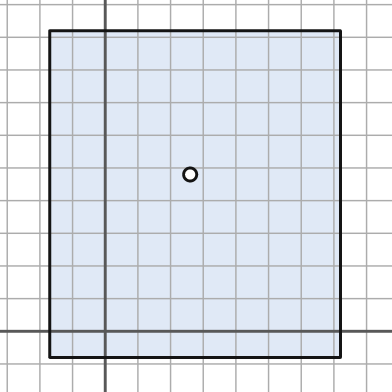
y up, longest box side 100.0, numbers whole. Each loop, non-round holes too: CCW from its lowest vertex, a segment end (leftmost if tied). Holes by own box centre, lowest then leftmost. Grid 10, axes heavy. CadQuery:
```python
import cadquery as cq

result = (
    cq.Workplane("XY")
    .moveTo(-17.0, -8.0)
    .lineTo(72.0, -8.0)
    .lineTo(72.0, 92.0)
    .lineTo(-17.0, 92.0)
    .close()
    .moveTo(26.0, 48.0)
    .circle(2.0)
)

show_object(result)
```